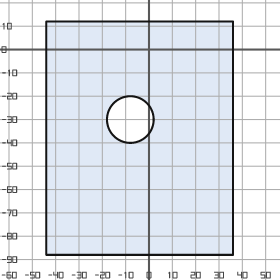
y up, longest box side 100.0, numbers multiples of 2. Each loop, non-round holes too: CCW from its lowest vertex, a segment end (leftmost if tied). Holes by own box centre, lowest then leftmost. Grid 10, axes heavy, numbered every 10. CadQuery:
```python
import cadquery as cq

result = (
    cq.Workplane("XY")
    .moveTo(-44.0, -88.0)
    .lineTo(36.0, -88.0)
    .lineTo(36.0, 12.0)
    .lineTo(-44.0, 12.0)
    .close()
    .moveTo(-8.0, -30.0)
    .circle(10.0)
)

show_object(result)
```